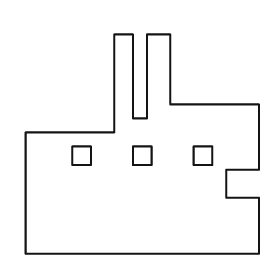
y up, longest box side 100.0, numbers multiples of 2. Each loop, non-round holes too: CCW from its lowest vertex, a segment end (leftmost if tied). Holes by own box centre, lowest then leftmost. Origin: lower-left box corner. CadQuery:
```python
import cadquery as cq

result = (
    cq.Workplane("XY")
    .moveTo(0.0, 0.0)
    .lineTo(100.0, 0.0)
    .lineTo(100.0, 24.0)
    .lineTo(86.0, 24.0)
    .lineTo(86.0, 36.0)
    .lineTo(100.0, 36.0)
    .lineTo(100.0, 64.0)
    .lineTo(62.0, 64.0)
    .lineTo(62.0, 94.0)
    .lineTo(52.0, 94.0)
    .lineTo(52.0, 58.0)
    .lineTo(46.0, 58.0)
    .lineTo(46.0, 94.0)
    .lineTo(38.0, 94.0)
    .lineTo(38.0, 52.0)
    .lineTo(0.0, 52.0)
    .close()
    .moveTo(20.0, 38.0)
    .lineTo(28.0, 38.0)
    .lineTo(28.0, 46.0)
    .lineTo(20.0, 46.0)
    .close()
    .moveTo(46.0, 38.0)
    .lineTo(54.0, 38.0)
    .lineTo(54.0, 46.0)
    .lineTo(46.0, 46.0)
    .close()
    .moveTo(72.0, 38.0)
    .lineTo(80.0, 38.0)
    .lineTo(80.0, 46.0)
    .lineTo(72.0, 46.0)
    .close()
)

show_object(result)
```